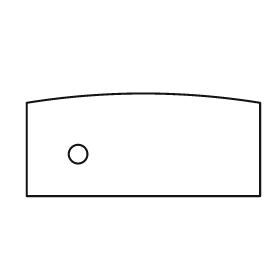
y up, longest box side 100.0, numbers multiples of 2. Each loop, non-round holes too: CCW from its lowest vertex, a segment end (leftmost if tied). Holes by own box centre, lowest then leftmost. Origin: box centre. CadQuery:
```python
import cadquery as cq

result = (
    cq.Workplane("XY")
    .moveTo(-50.0, -22.0)
    .lineTo(50.0, -22.0)
    .lineTo(50.0, 18.0)
    .threePointArc((0.0, 22.0), (-50.0, 18.0))
    .close()
    .moveTo(-28.0, -4.0)
    .circle(4.0)
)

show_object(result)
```